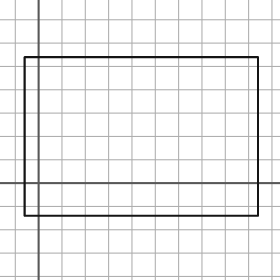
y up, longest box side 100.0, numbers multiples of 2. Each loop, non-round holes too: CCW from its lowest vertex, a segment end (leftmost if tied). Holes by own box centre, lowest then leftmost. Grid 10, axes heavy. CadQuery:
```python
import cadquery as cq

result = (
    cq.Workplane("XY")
    .moveTo(-6.0, -14.0)
    .lineTo(94.0, -14.0)
    .lineTo(94.0, 54.0)
    .lineTo(-6.0, 54.0)
    .close()
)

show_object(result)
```